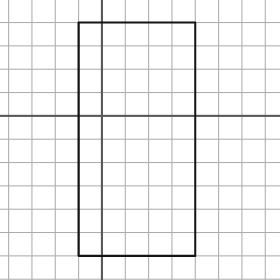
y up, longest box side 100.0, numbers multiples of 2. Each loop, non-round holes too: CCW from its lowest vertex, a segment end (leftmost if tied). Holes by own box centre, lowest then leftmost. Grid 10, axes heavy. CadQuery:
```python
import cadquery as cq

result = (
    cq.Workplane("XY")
    .moveTo(-10.0, -60.0)
    .lineTo(40.0, -60.0)
    .lineTo(40.0, 40.0)
    .lineTo(-10.0, 40.0)
    .close()
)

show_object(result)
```